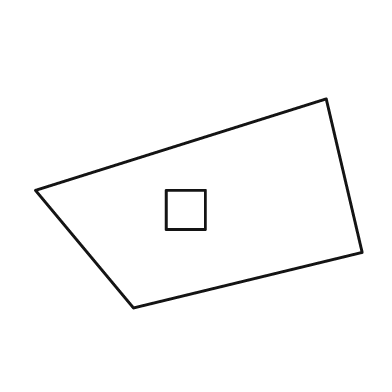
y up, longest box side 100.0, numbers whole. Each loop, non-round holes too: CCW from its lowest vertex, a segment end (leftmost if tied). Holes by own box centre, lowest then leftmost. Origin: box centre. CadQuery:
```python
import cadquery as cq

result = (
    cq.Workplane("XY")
    .moveTo(-20.0, -32.0)
    .lineTo(50.0, -15.0)
    .lineTo(39.0, 32.0)
    .lineTo(-50.0, 4.0)
    .close()
    .moveTo(-10.0, -8.0)
    .lineTo(2.0, -8.0)
    .lineTo(2.0, 4.0)
    .lineTo(-10.0, 4.0)
    .close()
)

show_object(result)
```